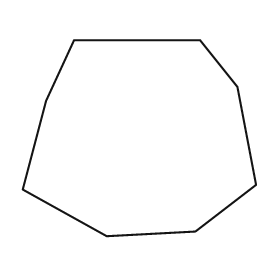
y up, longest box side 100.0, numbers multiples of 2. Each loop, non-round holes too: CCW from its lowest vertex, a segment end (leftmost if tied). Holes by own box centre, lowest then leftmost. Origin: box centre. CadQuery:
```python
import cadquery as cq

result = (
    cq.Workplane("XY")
    .moveTo(-14.0, -42.0)
    .lineTo(24.0, -40.0)
    .lineTo(50.0, -20.0)
    .lineTo(42.0, 22.0)
    .lineTo(26.0, 42.0)
    .lineTo(-28.0, 42.0)
    .lineTo(-40.0, 16.0)
    .lineTo(-50.0, -22.0)
    .close()
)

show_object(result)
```